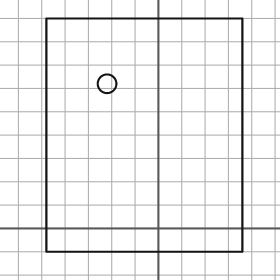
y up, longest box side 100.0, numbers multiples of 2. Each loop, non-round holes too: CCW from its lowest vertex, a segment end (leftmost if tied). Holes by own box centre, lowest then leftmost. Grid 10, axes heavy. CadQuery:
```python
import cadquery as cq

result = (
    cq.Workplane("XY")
    .moveTo(-48.0, -10.0)
    .lineTo(36.0, -10.0)
    .lineTo(36.0, 90.0)
    .lineTo(-48.0, 90.0)
    .close()
    .moveTo(-22.0, 62.0)
    .circle(4.0)
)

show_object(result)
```